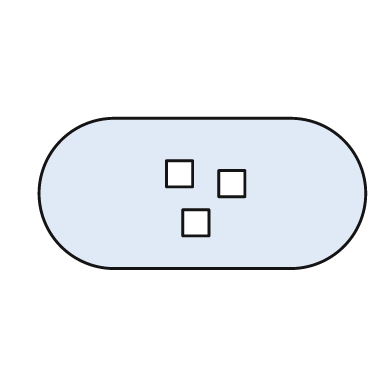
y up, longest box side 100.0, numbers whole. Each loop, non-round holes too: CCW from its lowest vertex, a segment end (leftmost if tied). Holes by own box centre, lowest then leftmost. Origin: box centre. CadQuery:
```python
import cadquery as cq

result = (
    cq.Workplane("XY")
    .moveTo(-27.0, -23.0)
    .lineTo(27.0, -23.0)
    .threePointArc((50.0, 0.0), (27.0, 23.0))
    .lineTo(-27.0, 23.0)
    .threePointArc((-50.0, 0.0), (-27.0, -23.0))
    .close()
    .moveTo(-6.0, -13.0)
    .lineTo(2.0, -13.0)
    .lineTo(2.0, -5.0)
    .lineTo(-6.0, -5.0)
    .close()
    .moveTo(5.0, -1.0)
    .lineTo(13.0, -1.0)
    .lineTo(13.0, 7.0)
    .lineTo(5.0, 7.0)
    .close()
    .moveTo(-11.0, 2.0)
    .lineTo(-3.0, 2.0)
    .lineTo(-3.0, 10.0)
    .lineTo(-11.0, 10.0)
    .close()
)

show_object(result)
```